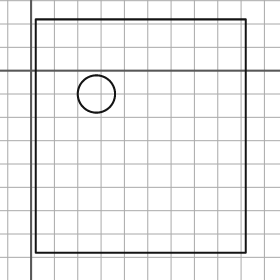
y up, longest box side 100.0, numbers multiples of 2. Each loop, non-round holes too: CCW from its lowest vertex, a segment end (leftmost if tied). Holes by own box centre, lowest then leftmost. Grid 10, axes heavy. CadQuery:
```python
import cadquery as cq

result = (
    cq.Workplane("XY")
    .moveTo(2.0, -78.0)
    .lineTo(92.0, -78.0)
    .lineTo(92.0, 22.0)
    .lineTo(2.0, 22.0)
    .close()
    .moveTo(28.0, -10.0)
    .circle(8.0)
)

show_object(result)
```